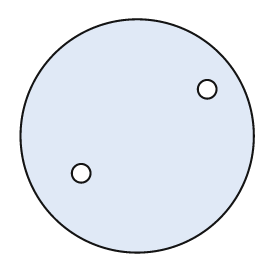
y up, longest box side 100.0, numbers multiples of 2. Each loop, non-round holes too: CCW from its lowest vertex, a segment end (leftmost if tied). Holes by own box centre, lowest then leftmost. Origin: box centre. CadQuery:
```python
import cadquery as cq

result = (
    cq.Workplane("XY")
    .moveTo(0.0, 0.0)
    .circle(50.0)
    .moveTo(-24.0, -16.0)
    .circle(4.0)
    .moveTo(30.0, 20.0)
    .circle(4.0)
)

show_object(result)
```